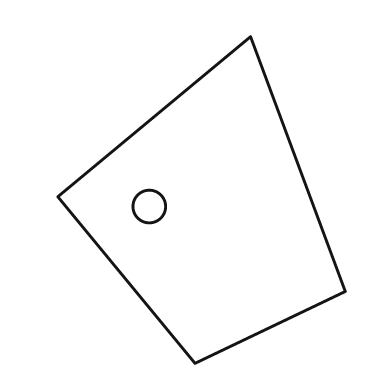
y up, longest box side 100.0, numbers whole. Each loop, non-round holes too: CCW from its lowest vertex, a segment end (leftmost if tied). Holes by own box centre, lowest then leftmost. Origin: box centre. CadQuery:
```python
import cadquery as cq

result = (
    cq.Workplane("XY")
    .moveTo(-2.0, -50.0)
    .lineTo(44.0, -28.0)
    .lineTo(15.0, 50.0)
    .lineTo(-44.0, 1.0)
    .close()
    .moveTo(-16.0, -2.0)
    .circle(5.0)
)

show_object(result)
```